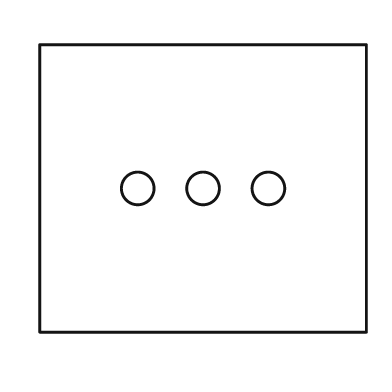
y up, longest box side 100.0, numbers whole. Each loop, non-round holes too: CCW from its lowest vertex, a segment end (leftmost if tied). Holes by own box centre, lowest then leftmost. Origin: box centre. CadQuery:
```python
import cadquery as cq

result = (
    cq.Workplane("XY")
    .moveTo(-50.0, -44.0)
    .lineTo(50.0, -44.0)
    .lineTo(50.0, 44.0)
    .lineTo(-50.0, 44.0)
    .close()
    .moveTo(-20.0, 0.0)
    .circle(5.0)
    .moveTo(0.0, 0.0)
    .circle(5.0)
    .moveTo(20.0, 0.0)
    .circle(5.0)
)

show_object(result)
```